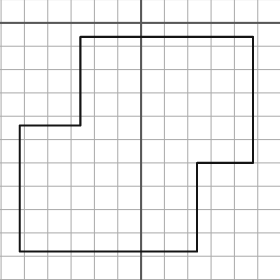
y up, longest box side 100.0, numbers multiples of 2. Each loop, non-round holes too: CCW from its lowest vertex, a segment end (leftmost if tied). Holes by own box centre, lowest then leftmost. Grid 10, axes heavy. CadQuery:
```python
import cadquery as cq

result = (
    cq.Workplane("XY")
    .moveTo(-52.0, -98.0)
    .lineTo(24.0, -98.0)
    .lineTo(24.0, -60.0)
    .lineTo(48.0, -60.0)
    .lineTo(48.0, -6.0)
    .lineTo(-26.0, -6.0)
    .lineTo(-26.0, -44.0)
    .lineTo(-52.0, -44.0)
    .close()
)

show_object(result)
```